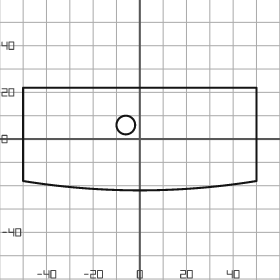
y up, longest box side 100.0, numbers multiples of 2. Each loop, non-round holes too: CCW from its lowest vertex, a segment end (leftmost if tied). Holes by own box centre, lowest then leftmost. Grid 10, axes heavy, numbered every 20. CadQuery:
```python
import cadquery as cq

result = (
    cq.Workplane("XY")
    .moveTo(-50.0, -18.0)
    .threePointArc((0.0, -22.0), (50.0, -18.0))
    .lineTo(50.0, 22.0)
    .lineTo(-50.0, 22.0)
    .close()
    .moveTo(-6.0, 6.0)
    .circle(4.0)
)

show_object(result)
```